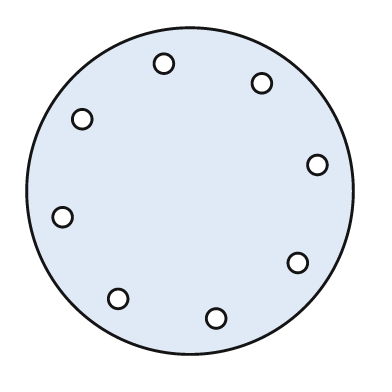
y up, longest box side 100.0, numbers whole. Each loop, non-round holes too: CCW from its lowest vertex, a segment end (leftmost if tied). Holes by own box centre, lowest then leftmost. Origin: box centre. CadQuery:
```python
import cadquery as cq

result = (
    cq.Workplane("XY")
    .moveTo(0.0, 0.0)
    .circle(50.0)
    .moveTo(8.0, -39.0)
    .circle(3.0)
    .moveTo(-22.0, -33.0)
    .circle(3.0)
    .moveTo(33.0, -22.0)
    .circle(3.0)
    .moveTo(-39.0, -8.0)
    .circle(3.0)
    .moveTo(39.0, 8.0)
    .circle(3.0)
    .moveTo(-33.0, 22.0)
    .circle(3.0)
    .moveTo(22.0, 33.0)
    .circle(3.0)
    .moveTo(-8.0, 39.0)
    .circle(3.0)
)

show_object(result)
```